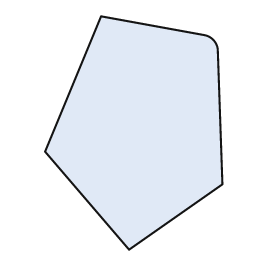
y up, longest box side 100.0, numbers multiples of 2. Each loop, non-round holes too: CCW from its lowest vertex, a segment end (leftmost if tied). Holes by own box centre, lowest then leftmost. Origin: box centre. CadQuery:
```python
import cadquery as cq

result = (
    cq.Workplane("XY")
    .moveTo(-2.0, -50.0)
    .lineTo(38.0, -22.0)
    .lineTo(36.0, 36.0)
    .threePointArc((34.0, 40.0), (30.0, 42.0))
    .lineTo(-14.0, 50.0)
    .lineTo(-38.0, -8.0)
    .close()
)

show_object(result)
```